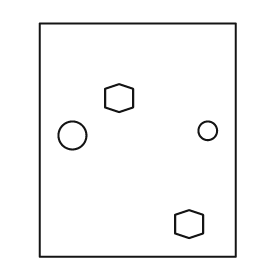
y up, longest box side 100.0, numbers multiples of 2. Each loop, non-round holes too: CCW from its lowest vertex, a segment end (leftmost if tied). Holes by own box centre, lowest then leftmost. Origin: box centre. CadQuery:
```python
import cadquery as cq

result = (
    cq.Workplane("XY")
    .moveTo(-42.0, -50.0)
    .lineTo(42.0, -50.0)
    .lineTo(42.0, 50.0)
    .lineTo(-42.0, 50.0)
    .close()
    .moveTo(22.0, -42.0)
    .lineTo(28.0, -40.0)
    .lineTo(28.0, -32.0)
    .lineTo(22.0, -30.0)
    .lineTo(16.0, -32.0)
    .lineTo(16.0, -40.0)
    .close()
    .moveTo(-28.0, 2.0)
    .circle(6.0)
    .moveTo(30.0, 4.0)
    .circle(4.0)
    .moveTo(-8.0, 12.0)
    .lineTo(-2.0, 14.0)
    .lineTo(-2.0, 22.0)
    .lineTo(-8.0, 24.0)
    .lineTo(-14.0, 22.0)
    .lineTo(-14.0, 14.0)
    .close()
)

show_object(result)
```